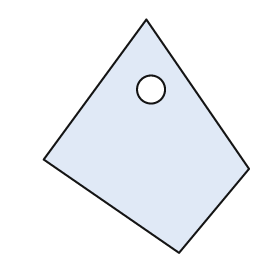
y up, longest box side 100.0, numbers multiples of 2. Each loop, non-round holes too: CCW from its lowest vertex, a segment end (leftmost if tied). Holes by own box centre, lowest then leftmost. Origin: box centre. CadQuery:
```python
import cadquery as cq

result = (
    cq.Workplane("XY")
    .moveTo(14.0, -50.0)
    .lineTo(44.0, -14.0)
    .lineTo(0.0, 50.0)
    .lineTo(-44.0, -10.0)
    .close()
    .moveTo(2.0, 20.0)
    .circle(6.0)
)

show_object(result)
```